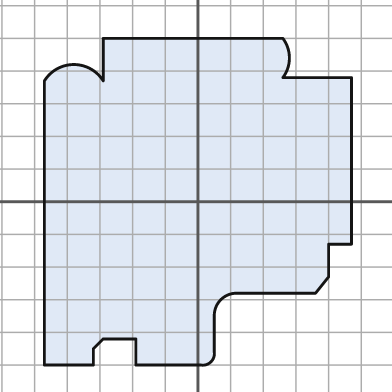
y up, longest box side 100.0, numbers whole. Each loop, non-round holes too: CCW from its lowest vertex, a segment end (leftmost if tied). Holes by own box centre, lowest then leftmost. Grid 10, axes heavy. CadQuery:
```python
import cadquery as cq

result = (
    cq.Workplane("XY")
    .moveTo(-47.0, -50.0)
    .lineTo(-32.0, -50.0)
    .lineTo(-32.0, -45.0)
    .lineTo(-29.0, -42.0)
    .lineTo(-19.0, -42.0)
    .lineTo(-19.0, -50.0)
    .lineTo(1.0, -50.0)
    .threePointArc((4.0, -49.0), (5.0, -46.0))
    .lineTo(5.0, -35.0)
    .threePointArc((7.0, -30.0), (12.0, -28.0))
    .lineTo(36.0, -28.0)
    .lineTo(40.0, -23.0)
    .lineTo(40.0, -13.0)
    .lineTo(47.0, -13.0)
    .lineTo(47.0, 38.0)
    .lineTo(26.0, 38.0)
    .threePointArc((28.0, 44.0), (26.0, 50.0))
    .lineTo(-29.0, 50.0)
    .lineTo(-29.0, 37.0)
    .threePointArc((-38.0, 42.0), (-47.0, 37.0))
    .close()
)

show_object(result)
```